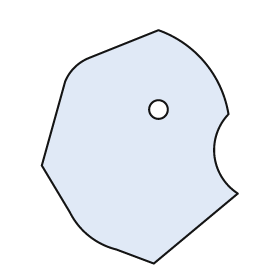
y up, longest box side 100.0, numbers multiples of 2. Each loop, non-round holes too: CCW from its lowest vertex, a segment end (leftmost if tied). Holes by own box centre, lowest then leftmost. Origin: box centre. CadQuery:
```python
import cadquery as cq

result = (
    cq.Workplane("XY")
    .moveTo(6.0, -50.0)
    .lineTo(42.0, -20.0)
    .threePointArc((32.0, -4.0), (38.0, 14.0))
    .threePointArc((28.0, 36.0), (8.0, 50.0))
    .lineTo(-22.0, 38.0)
    .threePointArc((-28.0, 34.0), (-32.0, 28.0))
    .lineTo(-42.0, -8.0)
    .lineTo(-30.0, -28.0)
    .threePointArc((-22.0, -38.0), (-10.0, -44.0))
    .close()
    .moveTo(8.0, 16.0)
    .circle(4.0)
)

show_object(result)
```